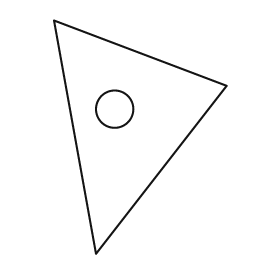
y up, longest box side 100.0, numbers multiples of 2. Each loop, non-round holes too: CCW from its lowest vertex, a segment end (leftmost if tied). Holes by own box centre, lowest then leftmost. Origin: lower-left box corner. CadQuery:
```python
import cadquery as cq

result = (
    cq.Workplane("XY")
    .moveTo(18.0, 0.0)
    .lineTo(74.0, 72.0)
    .lineTo(0.0, 100.0)
    .close()
    .moveTo(26.0, 62.0)
    .circle(8.0)
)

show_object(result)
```